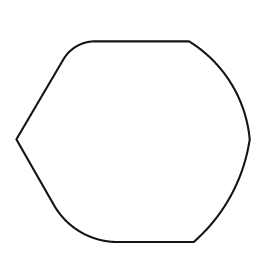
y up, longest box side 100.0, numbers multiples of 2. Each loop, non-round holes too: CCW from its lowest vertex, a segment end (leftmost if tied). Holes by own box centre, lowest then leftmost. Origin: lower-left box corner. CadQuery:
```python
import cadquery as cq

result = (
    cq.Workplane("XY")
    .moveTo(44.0, 0.0)
    .lineTo(76.0, 0.0)
    .threePointArc((92.0, 20.0), (100.0, 44.0))
    .threePointArc((92.0, 68.0), (74.0, 86.0))
    .lineTo(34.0, 86.0)
    .threePointArc((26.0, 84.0), (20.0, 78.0))
    .lineTo(0.0, 44.0)
    .lineTo(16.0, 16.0)
    .threePointArc((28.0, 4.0), (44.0, 0.0))
    .close()
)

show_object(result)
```